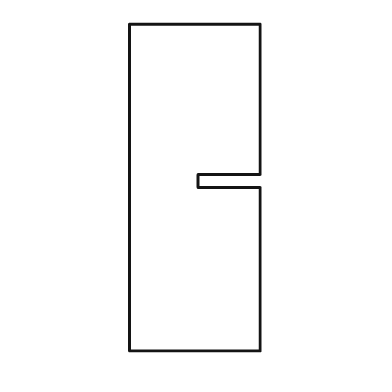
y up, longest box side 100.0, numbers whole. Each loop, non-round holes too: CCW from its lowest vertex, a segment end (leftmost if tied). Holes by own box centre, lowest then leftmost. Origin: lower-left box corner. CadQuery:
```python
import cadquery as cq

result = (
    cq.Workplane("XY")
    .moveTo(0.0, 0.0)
    .lineTo(40.0, 0.0)
    .lineTo(40.0, 50.0)
    .lineTo(21.0, 50.0)
    .lineTo(21.0, 54.0)
    .lineTo(40.0, 54.0)
    .lineTo(40.0, 100.0)
    .lineTo(0.0, 100.0)
    .close()
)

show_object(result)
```